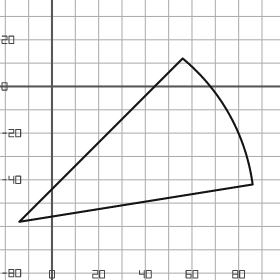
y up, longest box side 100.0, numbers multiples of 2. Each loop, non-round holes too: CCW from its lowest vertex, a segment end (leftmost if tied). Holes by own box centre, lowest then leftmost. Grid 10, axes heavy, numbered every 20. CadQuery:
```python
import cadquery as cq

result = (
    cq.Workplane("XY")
    .moveTo(-14.0, -58.0)
    .lineTo(86.0, -42.0)
    .threePointArc((76.0, -12.0), (56.0, 12.0))
    .close()
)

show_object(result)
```